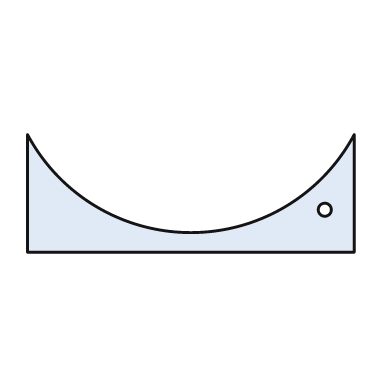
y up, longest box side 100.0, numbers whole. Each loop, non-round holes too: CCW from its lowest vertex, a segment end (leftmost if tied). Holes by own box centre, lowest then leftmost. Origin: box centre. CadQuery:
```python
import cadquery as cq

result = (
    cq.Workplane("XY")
    .moveTo(-50.0, -18.0)
    .lineTo(50.0, -18.0)
    .lineTo(50.0, 18.0)
    .threePointArc((0.0, -12.0), (-50.0, 18.0))
    .close()
    .moveTo(41.0, -5.0)
    .circle(2.0)
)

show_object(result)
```